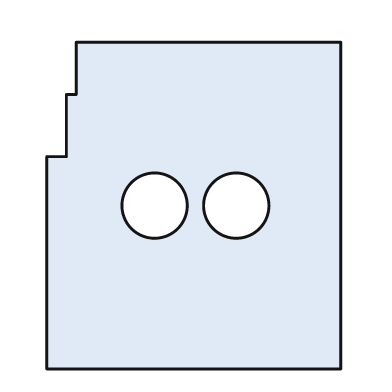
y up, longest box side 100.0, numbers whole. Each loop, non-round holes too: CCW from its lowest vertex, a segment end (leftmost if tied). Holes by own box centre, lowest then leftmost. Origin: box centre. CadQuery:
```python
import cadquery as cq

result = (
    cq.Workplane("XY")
    .moveTo(-45.0, -50.0)
    .lineTo(45.0, -50.0)
    .lineTo(45.0, 50.0)
    .lineTo(-36.0, 50.0)
    .lineTo(-36.0, 34.0)
    .lineTo(-39.0, 34.0)
    .lineTo(-39.0, 15.0)
    .lineTo(-45.0, 15.0)
    .close()
    .moveTo(-12.0, 0.0)
    .circle(10.0)
    .moveTo(13.0, 0.0)
    .circle(10.0)
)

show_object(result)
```